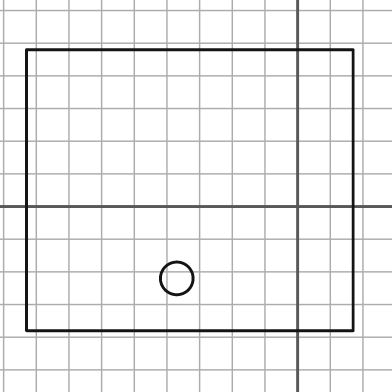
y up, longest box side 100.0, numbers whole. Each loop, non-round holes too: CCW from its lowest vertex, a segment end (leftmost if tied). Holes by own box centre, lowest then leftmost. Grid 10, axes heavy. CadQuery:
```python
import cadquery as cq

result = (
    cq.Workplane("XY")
    .moveTo(-83.0, -38.0)
    .lineTo(17.0, -38.0)
    .lineTo(17.0, 48.0)
    .lineTo(-83.0, 48.0)
    .close()
    .moveTo(-37.0, -22.0)
    .circle(5.0)
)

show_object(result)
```